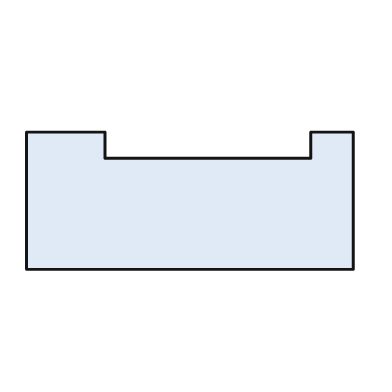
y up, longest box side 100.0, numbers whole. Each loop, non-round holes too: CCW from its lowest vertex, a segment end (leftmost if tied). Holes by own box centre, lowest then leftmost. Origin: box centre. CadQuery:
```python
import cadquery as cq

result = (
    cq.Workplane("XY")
    .moveTo(-50.0, -21.0)
    .lineTo(50.0, -21.0)
    .lineTo(50.0, 21.0)
    .lineTo(37.0, 21.0)
    .lineTo(37.0, 13.0)
    .lineTo(-26.0, 13.0)
    .lineTo(-26.0, 21.0)
    .lineTo(-50.0, 21.0)
    .close()
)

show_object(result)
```